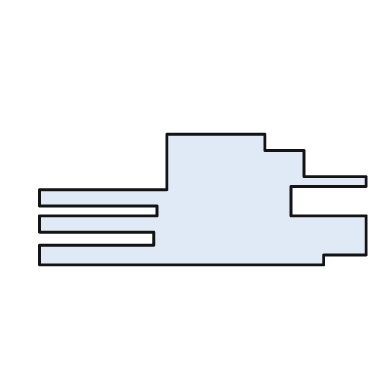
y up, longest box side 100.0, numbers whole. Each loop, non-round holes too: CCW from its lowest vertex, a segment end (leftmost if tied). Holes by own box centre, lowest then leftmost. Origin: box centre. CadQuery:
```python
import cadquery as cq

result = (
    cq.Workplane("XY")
    .moveTo(-50.0, -20.0)
    .lineTo(37.0, -20.0)
    .lineTo(37.0, -17.0)
    .lineTo(50.0, -17.0)
    .lineTo(50.0, -5.0)
    .lineTo(27.0, -5.0)
    .lineTo(27.0, 4.0)
    .lineTo(50.0, 4.0)
    .lineTo(50.0, 7.0)
    .lineTo(31.0, 7.0)
    .lineTo(31.0, 15.0)
    .lineTo(19.0, 15.0)
    .lineTo(19.0, 20.0)
    .lineTo(-11.0, 20.0)
    .lineTo(-11.0, 3.0)
    .lineTo(-50.0, 3.0)
    .lineTo(-50.0, -2.0)
    .lineTo(-14.0, -2.0)
    .lineTo(-14.0, -5.0)
    .lineTo(-50.0, -5.0)
    .lineTo(-50.0, -10.0)
    .lineTo(-15.0, -10.0)
    .lineTo(-15.0, -14.0)
    .lineTo(-50.0, -14.0)
    .close()
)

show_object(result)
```